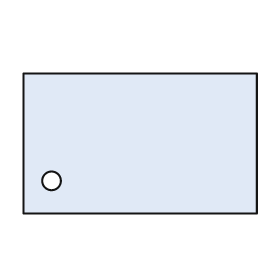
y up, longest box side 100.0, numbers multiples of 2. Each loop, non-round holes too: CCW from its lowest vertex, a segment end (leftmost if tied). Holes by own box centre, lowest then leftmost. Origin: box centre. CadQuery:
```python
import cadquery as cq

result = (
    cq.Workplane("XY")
    .moveTo(-50.0, -30.0)
    .lineTo(50.0, -30.0)
    .lineTo(50.0, 30.0)
    .lineTo(-50.0, 30.0)
    .close()
    .moveTo(-38.0, -16.0)
    .circle(4.0)
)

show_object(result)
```